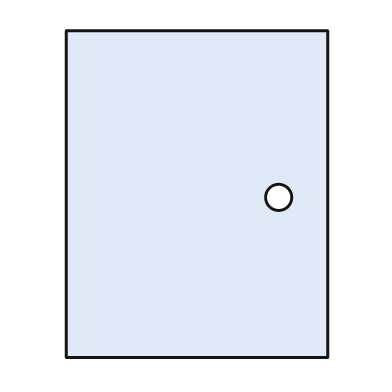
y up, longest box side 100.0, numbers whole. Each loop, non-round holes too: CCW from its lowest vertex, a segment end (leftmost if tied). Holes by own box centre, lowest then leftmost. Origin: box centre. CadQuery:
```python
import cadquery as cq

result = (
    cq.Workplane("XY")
    .moveTo(-40.0, -50.0)
    .lineTo(40.0, -50.0)
    .lineTo(40.0, 50.0)
    .lineTo(-40.0, 50.0)
    .close()
    .moveTo(25.0, -1.0)
    .circle(4.0)
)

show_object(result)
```